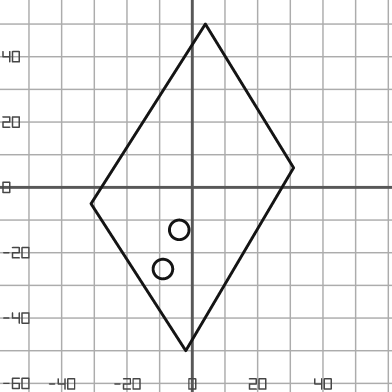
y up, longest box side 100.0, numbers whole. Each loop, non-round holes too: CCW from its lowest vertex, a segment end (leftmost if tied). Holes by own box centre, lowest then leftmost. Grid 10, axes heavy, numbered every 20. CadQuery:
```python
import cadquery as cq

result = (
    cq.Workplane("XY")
    .moveTo(-2.0, -50.0)
    .lineTo(31.0, 6.0)
    .lineTo(4.0, 50.0)
    .lineTo(-31.0, -5.0)
    .close()
    .moveTo(-9.0, -25.0)
    .circle(3.0)
    .moveTo(-4.0, -13.0)
    .circle(3.0)
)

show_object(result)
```